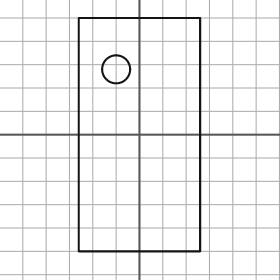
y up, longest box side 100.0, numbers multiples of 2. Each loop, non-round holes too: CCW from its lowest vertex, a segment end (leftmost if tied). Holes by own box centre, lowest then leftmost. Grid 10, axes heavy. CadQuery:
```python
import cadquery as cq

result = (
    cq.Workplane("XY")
    .moveTo(-26.0, -50.0)
    .lineTo(26.0, -50.0)
    .lineTo(26.0, 50.0)
    .lineTo(-26.0, 50.0)
    .close()
    .moveTo(-10.0, 28.0)
    .circle(6.0)
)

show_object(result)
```